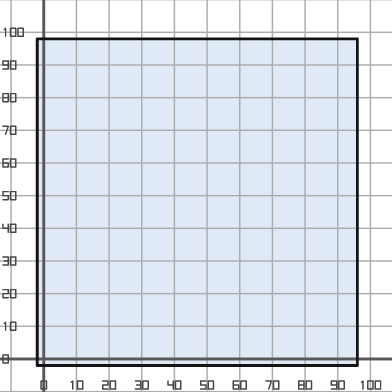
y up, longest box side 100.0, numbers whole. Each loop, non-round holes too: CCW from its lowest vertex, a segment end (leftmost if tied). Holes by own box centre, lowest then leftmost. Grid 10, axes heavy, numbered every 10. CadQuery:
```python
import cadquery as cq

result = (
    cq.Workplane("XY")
    .moveTo(-2.0, -2.0)
    .lineTo(96.0, -2.0)
    .lineTo(96.0, 98.0)
    .lineTo(-2.0, 98.0)
    .close()
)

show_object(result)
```